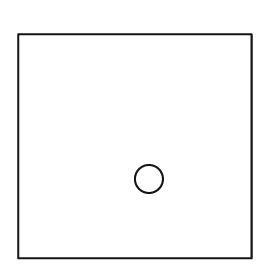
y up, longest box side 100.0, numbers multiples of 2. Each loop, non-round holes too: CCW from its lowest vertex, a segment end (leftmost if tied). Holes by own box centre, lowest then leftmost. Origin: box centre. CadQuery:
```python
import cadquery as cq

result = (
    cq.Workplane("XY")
    .moveTo(-50.0, -48.0)
    .lineTo(50.0, -48.0)
    .lineTo(50.0, 48.0)
    .lineTo(-50.0, 48.0)
    .close()
    .moveTo(6.0, -14.0)
    .circle(6.0)
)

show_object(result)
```